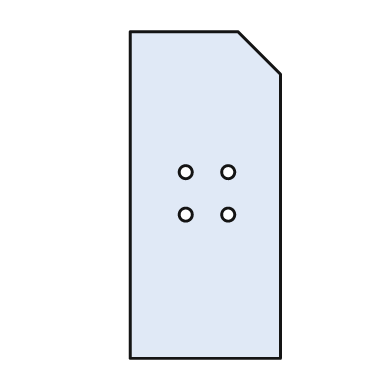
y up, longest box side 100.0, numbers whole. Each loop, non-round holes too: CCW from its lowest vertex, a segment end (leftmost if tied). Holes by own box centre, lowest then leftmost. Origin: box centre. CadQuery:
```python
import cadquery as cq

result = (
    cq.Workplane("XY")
    .moveTo(-23.0, -50.0)
    .lineTo(23.0, -50.0)
    .lineTo(23.0, 37.0)
    .lineTo(10.0, 50.0)
    .lineTo(-23.0, 50.0)
    .close()
    .moveTo(-6.0, -6.0)
    .circle(2.0)
    .moveTo(7.0, -6.0)
    .circle(2.0)
    .moveTo(-6.0, 7.0)
    .circle(2.0)
    .moveTo(7.0, 7.0)
    .circle(2.0)
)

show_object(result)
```